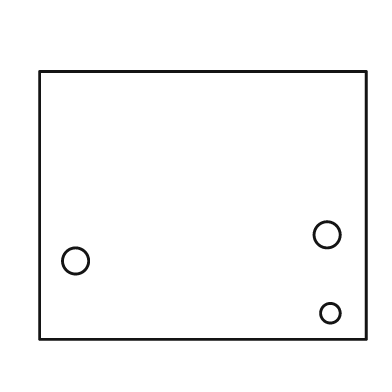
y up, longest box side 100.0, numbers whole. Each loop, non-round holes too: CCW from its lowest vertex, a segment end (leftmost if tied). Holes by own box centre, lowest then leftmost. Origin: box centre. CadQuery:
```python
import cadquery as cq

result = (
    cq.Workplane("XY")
    .moveTo(-50.0, -41.0)
    .lineTo(50.0, -41.0)
    .lineTo(50.0, 41.0)
    .lineTo(-50.0, 41.0)
    .close()
    .moveTo(39.0, -33.0)
    .circle(3.0)
    .moveTo(-39.0, -17.0)
    .circle(4.0)
    .moveTo(38.0, -9.0)
    .circle(4.0)
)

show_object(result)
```